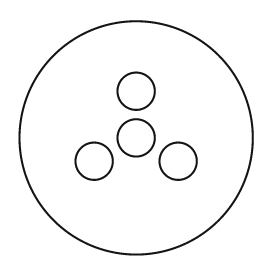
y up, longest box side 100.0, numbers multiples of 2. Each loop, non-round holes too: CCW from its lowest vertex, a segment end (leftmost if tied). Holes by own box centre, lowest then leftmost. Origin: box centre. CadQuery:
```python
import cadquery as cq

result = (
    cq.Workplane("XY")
    .moveTo(0.0, 0.0)
    .circle(50.0)
    .moveTo(-18.0, -10.0)
    .circle(8.0)
    .moveTo(18.0, -10.0)
    .circle(8.0)
    .moveTo(0.0, 0.0)
    .circle(8.0)
    .moveTo(0.0, 20.0)
    .circle(8.0)
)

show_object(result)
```